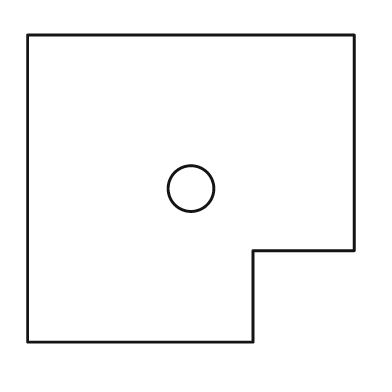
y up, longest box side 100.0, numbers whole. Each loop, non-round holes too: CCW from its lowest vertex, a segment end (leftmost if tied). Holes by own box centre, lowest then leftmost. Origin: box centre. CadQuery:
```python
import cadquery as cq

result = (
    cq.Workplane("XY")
    .moveTo(-50.0, -47.0)
    .lineTo(19.0, -47.0)
    .lineTo(19.0, -19.0)
    .lineTo(50.0, -19.0)
    .lineTo(50.0, 47.0)
    .lineTo(-50.0, 47.0)
    .close()
    .moveTo(0.0, 0.0)
    .circle(7.0)
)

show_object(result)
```